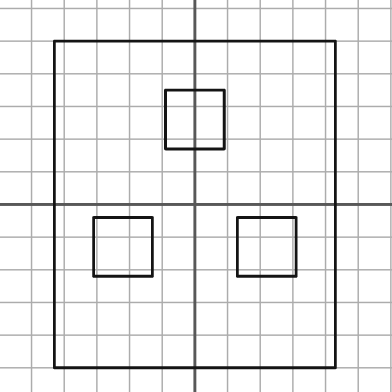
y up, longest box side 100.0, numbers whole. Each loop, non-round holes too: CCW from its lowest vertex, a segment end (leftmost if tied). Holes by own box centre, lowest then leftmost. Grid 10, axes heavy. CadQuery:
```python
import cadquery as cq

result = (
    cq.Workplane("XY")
    .moveTo(-43.0, -50.0)
    .lineTo(43.0, -50.0)
    .lineTo(43.0, 50.0)
    .lineTo(-43.0, 50.0)
    .close()
    .moveTo(-31.0, -22.0)
    .lineTo(-13.0, -22.0)
    .lineTo(-13.0, -4.0)
    .lineTo(-31.0, -4.0)
    .close()
    .moveTo(13.0, -22.0)
    .lineTo(31.0, -22.0)
    .lineTo(31.0, -4.0)
    .lineTo(13.0, -4.0)
    .close()
    .moveTo(-9.0, 17.0)
    .lineTo(9.0, 17.0)
    .lineTo(9.0, 35.0)
    .lineTo(-9.0, 35.0)
    .close()
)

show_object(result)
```